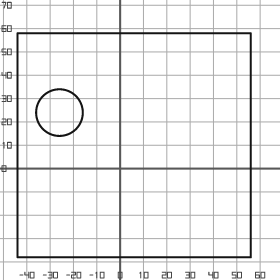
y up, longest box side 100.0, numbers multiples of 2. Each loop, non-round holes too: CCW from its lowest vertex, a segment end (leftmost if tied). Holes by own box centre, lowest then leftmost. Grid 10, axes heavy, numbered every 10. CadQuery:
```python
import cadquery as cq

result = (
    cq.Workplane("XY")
    .moveTo(-44.0, -38.0)
    .lineTo(56.0, -38.0)
    .lineTo(56.0, 58.0)
    .lineTo(-44.0, 58.0)
    .close()
    .moveTo(-26.0, 24.0)
    .circle(10.0)
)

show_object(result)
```